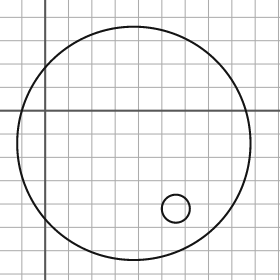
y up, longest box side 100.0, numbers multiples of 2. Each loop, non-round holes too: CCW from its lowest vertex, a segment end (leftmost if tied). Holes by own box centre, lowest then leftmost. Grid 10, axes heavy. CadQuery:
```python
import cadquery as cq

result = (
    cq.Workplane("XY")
    .moveTo(38.0, -14.0)
    .circle(50.0)
    .moveTo(56.0, -42.0)
    .circle(6.0)
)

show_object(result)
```